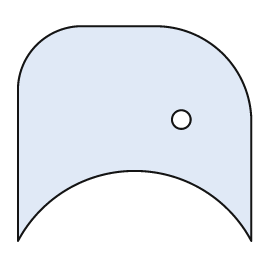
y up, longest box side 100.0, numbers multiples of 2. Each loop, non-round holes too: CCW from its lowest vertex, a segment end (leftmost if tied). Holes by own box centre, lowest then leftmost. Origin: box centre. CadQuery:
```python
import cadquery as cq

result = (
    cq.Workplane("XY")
    .moveTo(-50.0, -46.0)
    .threePointArc((0.0, -16.0), (50.0, -46.0))
    .lineTo(50.0, 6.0)
    .threePointArc((38.0, 34.0), (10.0, 46.0))
    .lineTo(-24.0, 46.0)
    .threePointArc((-42.0, 38.0), (-50.0, 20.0))
    .close()
    .moveTo(20.0, 6.0)
    .circle(4.0)
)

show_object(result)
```